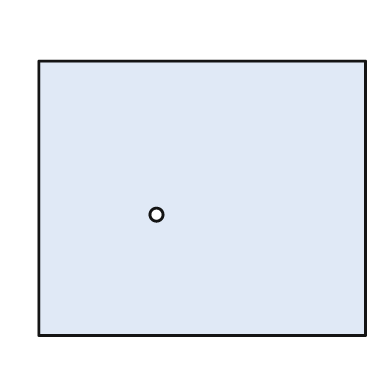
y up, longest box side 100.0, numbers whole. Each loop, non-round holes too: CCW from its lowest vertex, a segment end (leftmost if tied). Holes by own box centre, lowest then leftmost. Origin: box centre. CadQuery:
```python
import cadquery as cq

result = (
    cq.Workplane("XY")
    .moveTo(-50.0, -42.0)
    .lineTo(50.0, -42.0)
    .lineTo(50.0, 42.0)
    .lineTo(-50.0, 42.0)
    .close()
    .moveTo(-14.0, -5.0)
    .circle(2.0)
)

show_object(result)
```